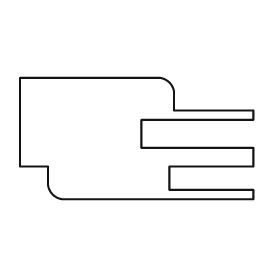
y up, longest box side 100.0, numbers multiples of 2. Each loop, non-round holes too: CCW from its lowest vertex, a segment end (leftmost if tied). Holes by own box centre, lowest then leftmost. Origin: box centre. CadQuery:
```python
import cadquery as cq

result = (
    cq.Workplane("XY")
    .moveTo(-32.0, -26.0)
    .lineTo(50.0, -26.0)
    .lineTo(50.0, -22.0)
    .lineTo(14.0, -22.0)
    .lineTo(14.0, -12.0)
    .lineTo(50.0, -12.0)
    .lineTo(50.0, -4.0)
    .lineTo(2.0, -4.0)
    .lineTo(2.0, 8.0)
    .lineTo(50.0, 8.0)
    .lineTo(50.0, 12.0)
    .lineTo(16.0, 12.0)
    .lineTo(16.0, 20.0)
    .threePointArc((14.0, 24.0), (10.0, 26.0))
    .lineTo(-50.0, 26.0)
    .lineTo(-50.0, -12.0)
    .lineTo(-38.0, -12.0)
    .lineTo(-38.0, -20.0)
    .threePointArc((-36.0, -24.0), (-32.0, -26.0))
    .close()
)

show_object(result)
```